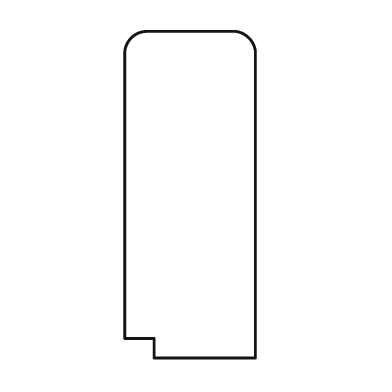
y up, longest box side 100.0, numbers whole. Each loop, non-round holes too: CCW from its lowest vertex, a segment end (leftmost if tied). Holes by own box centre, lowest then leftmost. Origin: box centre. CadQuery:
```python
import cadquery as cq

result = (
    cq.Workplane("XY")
    .moveTo(-11.0, -50.0)
    .lineTo(20.0, -50.0)
    .lineTo(20.0, 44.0)
    .threePointArc((18.0, 48.0), (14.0, 50.0))
    .lineTo(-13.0, 50.0)
    .threePointArc((-18.0, 48.0), (-20.0, 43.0))
    .lineTo(-20.0, -44.0)
    .lineTo(-11.0, -44.0)
    .close()
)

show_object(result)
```